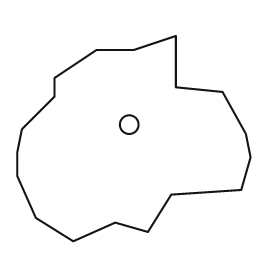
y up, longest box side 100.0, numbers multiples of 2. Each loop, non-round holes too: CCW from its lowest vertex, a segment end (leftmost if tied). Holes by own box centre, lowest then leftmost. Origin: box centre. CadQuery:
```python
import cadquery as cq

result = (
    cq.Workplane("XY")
    .moveTo(-26.0, -44.0)
    .lineTo(-8.0, -36.0)
    .lineTo(6.0, -40.0)
    .lineTo(16.0, -24.0)
    .lineTo(46.0, -22.0)
    .lineTo(50.0, -8.0)
    .lineTo(48.0, 2.0)
    .lineTo(38.0, 20.0)
    .lineTo(18.0, 22.0)
    .lineTo(18.0, 44.0)
    .lineTo(0.0, 38.0)
    .lineTo(-16.0, 38.0)
    .lineTo(-34.0, 26.0)
    .lineTo(-34.0, 18.0)
    .lineTo(-48.0, 4.0)
    .lineTo(-50.0, -6.0)
    .lineTo(-50.0, -16.0)
    .lineTo(-42.0, -34.0)
    .close()
    .moveTo(-2.0, 6.0)
    .circle(4.0)
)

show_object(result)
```